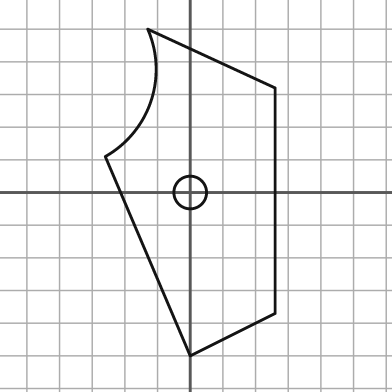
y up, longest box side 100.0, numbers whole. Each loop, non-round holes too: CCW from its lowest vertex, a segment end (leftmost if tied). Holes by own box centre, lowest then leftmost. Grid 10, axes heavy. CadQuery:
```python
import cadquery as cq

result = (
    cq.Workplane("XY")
    .moveTo(0.0, -50.0)
    .lineTo(26.0, -37.0)
    .lineTo(26.0, 32.0)
    .lineTo(-13.0, 50.0)
    .threePointArc((-12.0, 28.0), (-26.0, 11.0))
    .close()
    .moveTo(0.0, 0.0)
    .circle(5.0)
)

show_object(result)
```